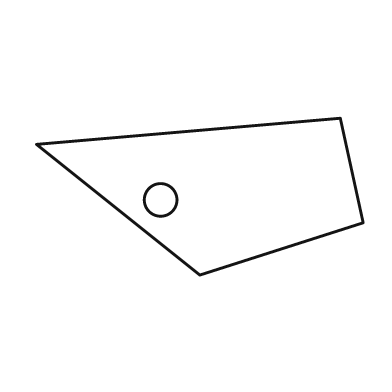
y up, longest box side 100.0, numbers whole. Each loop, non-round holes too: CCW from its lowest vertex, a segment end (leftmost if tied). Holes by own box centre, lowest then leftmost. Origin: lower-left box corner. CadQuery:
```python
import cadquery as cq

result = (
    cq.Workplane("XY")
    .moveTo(50.0, 0.0)
    .lineTo(100.0, 16.0)
    .lineTo(93.0, 48.0)
    .lineTo(0.0, 40.0)
    .close()
    .moveTo(38.0, 23.0)
    .circle(5.0)
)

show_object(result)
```